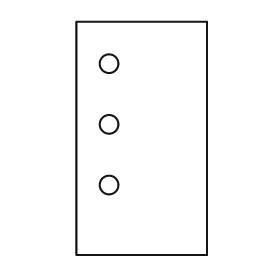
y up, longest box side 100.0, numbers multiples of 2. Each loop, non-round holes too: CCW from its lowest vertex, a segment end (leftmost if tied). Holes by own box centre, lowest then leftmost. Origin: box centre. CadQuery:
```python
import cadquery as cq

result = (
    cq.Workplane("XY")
    .moveTo(-28.0, -50.0)
    .lineTo(28.0, -50.0)
    .lineTo(28.0, 50.0)
    .lineTo(-28.0, 50.0)
    .close()
    .moveTo(-14.0, -20.0)
    .circle(4.0)
    .moveTo(-14.0, 6.0)
    .circle(4.0)
    .moveTo(-14.0, 32.0)
    .circle(4.0)
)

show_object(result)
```